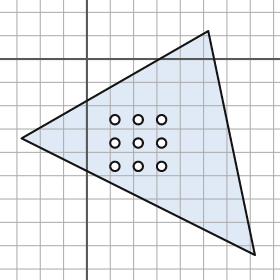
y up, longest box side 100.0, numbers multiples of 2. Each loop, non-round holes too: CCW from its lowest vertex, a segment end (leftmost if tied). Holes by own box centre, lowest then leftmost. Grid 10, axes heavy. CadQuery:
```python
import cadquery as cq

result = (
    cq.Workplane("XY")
    .moveTo(72.0, -84.0)
    .lineTo(52.0, 12.0)
    .lineTo(-28.0, -34.0)
    .close()
    .moveTo(12.0, -46.0)
    .circle(2.0)
    .moveTo(22.0, -46.0)
    .circle(2.0)
    .moveTo(32.0, -46.0)
    .circle(2.0)
    .moveTo(12.0, -36.0)
    .circle(2.0)
    .moveTo(22.0, -36.0)
    .circle(2.0)
    .moveTo(32.0, -36.0)
    .circle(2.0)
    .moveTo(12.0, -26.0)
    .circle(2.0)
    .moveTo(22.0, -26.0)
    .circle(2.0)
    .moveTo(32.0, -26.0)
    .circle(2.0)
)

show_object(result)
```